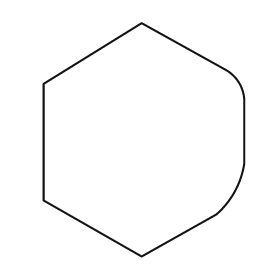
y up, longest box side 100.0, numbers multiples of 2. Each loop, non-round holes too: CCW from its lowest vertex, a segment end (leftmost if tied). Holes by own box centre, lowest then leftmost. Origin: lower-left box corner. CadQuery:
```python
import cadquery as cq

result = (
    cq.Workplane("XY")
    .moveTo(42.0, 0.0)
    .lineTo(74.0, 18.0)
    .threePointArc((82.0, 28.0), (86.0, 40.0))
    .lineTo(86.0, 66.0)
    .threePointArc((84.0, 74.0), (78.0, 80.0))
    .lineTo(42.0, 100.0)
    .lineTo(0.0, 74.0)
    .lineTo(0.0, 24.0)
    .close()
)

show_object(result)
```